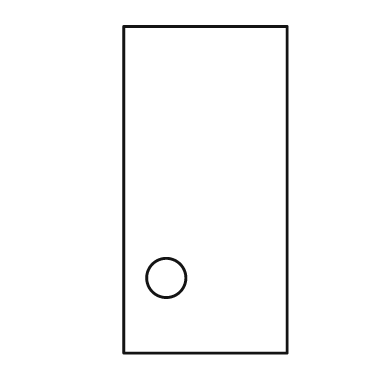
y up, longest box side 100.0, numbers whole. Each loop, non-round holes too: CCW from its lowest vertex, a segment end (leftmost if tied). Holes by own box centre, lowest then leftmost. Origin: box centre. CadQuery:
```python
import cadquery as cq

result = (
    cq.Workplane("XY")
    .moveTo(-25.0, -50.0)
    .lineTo(25.0, -50.0)
    .lineTo(25.0, 50.0)
    .lineTo(-25.0, 50.0)
    .close()
    .moveTo(-12.0, -27.0)
    .circle(6.0)
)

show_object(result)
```